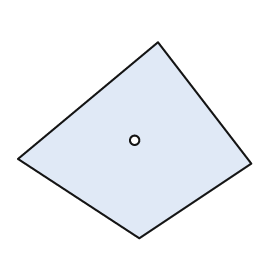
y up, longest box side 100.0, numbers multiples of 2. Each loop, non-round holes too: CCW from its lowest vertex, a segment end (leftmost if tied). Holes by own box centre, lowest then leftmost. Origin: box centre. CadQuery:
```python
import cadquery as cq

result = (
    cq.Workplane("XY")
    .moveTo(2.0, -42.0)
    .lineTo(50.0, -10.0)
    .lineTo(10.0, 42.0)
    .lineTo(-50.0, -8.0)
    .close()
    .moveTo(0.0, 0.0)
    .circle(2.0)
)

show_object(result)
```